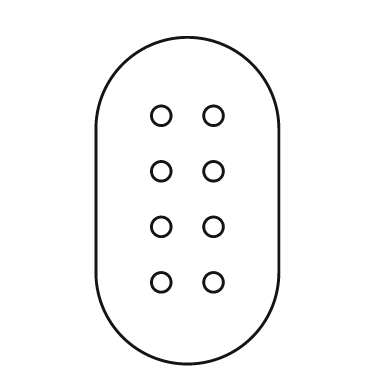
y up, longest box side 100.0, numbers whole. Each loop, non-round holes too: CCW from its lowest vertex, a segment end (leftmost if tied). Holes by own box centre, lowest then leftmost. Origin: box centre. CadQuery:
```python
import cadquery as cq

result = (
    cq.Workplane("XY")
    .moveTo(-28.0, -22.0)
    .threePointArc((0.0, -50.0), (28.0, -22.0))
    .lineTo(28.0, 22.0)
    .threePointArc((0.0, 50.0), (-28.0, 22.0))
    .close()
    .moveTo(-8.0, -25.0)
    .circle(3.0)
    .moveTo(8.0, -25.0)
    .circle(3.0)
    .moveTo(-8.0, -8.0)
    .circle(3.0)
    .moveTo(8.0, -8.0)
    .circle(3.0)
    .moveTo(-8.0, 9.0)
    .circle(3.0)
    .moveTo(8.0, 9.0)
    .circle(3.0)
    .moveTo(-8.0, 26.0)
    .circle(3.0)
    .moveTo(8.0, 26.0)
    .circle(3.0)
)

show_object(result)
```